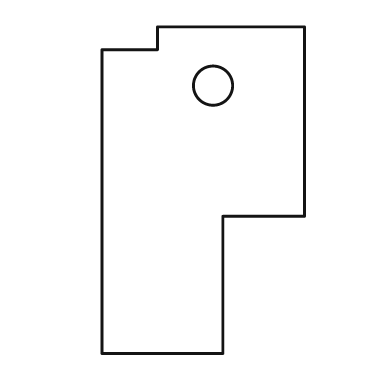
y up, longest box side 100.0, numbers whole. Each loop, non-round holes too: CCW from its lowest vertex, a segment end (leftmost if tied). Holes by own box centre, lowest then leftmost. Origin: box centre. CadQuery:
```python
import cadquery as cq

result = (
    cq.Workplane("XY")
    .moveTo(-31.0, -50.0)
    .lineTo(6.0, -50.0)
    .lineTo(6.0, -8.0)
    .lineTo(31.0, -8.0)
    .lineTo(31.0, 50.0)
    .lineTo(-14.0, 50.0)
    .lineTo(-14.0, 43.0)
    .lineTo(-31.0, 43.0)
    .close()
    .moveTo(3.0, 32.0)
    .circle(6.0)
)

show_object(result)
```